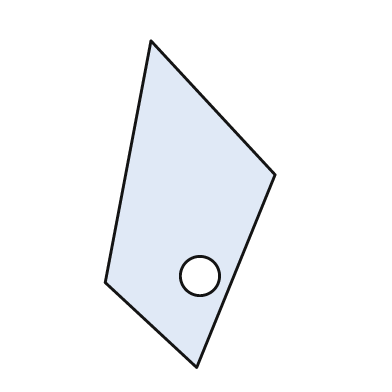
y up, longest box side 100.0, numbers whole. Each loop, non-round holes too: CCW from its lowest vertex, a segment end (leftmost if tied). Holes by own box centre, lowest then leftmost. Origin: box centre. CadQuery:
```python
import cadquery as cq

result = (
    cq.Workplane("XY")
    .moveTo(2.0, -50.0)
    .lineTo(26.0, 9.0)
    .lineTo(-12.0, 50.0)
    .lineTo(-26.0, -24.0)
    .close()
    .moveTo(3.0, -22.0)
    .circle(6.0)
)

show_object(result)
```